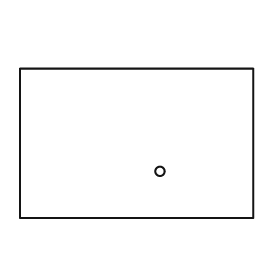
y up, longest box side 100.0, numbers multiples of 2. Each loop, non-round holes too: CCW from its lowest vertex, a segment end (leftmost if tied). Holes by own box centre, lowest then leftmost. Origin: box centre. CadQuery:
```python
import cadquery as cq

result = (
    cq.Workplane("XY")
    .moveTo(-50.0, -32.0)
    .lineTo(50.0, -32.0)
    .lineTo(50.0, 32.0)
    .lineTo(-50.0, 32.0)
    .close()
    .moveTo(10.0, -12.0)
    .circle(2.0)
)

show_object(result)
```